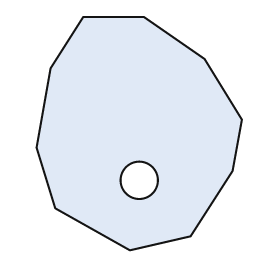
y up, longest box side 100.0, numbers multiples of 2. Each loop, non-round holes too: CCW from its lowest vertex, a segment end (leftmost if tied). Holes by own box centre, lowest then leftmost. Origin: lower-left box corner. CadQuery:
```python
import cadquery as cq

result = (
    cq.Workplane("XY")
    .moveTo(40.0, 0.0)
    .lineTo(66.0, 6.0)
    .lineTo(84.0, 34.0)
    .lineTo(88.0, 56.0)
    .lineTo(72.0, 82.0)
    .lineTo(46.0, 100.0)
    .lineTo(20.0, 100.0)
    .lineTo(6.0, 78.0)
    .lineTo(0.0, 44.0)
    .lineTo(8.0, 18.0)
    .close()
    .moveTo(44.0, 30.0)
    .circle(8.0)
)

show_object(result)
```